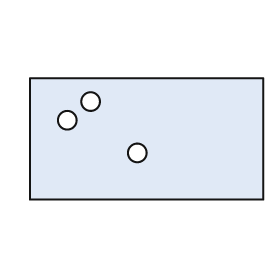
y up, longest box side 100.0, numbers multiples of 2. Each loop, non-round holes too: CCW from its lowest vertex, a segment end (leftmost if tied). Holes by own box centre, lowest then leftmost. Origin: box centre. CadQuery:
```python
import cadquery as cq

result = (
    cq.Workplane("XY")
    .moveTo(-50.0, -26.0)
    .lineTo(50.0, -26.0)
    .lineTo(50.0, 26.0)
    .lineTo(-50.0, 26.0)
    .close()
    .moveTo(-4.0, -6.0)
    .circle(4.0)
    .moveTo(-34.0, 8.0)
    .circle(4.0)
    .moveTo(-24.0, 16.0)
    .circle(4.0)
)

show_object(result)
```